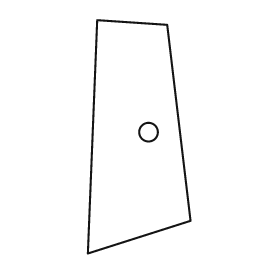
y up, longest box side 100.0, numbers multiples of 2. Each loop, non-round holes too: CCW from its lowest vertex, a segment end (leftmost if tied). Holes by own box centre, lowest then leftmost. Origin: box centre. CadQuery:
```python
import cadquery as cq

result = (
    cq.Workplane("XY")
    .moveTo(-22.0, -50.0)
    .lineTo(22.0, -36.0)
    .lineTo(12.0, 48.0)
    .lineTo(-18.0, 50.0)
    .close()
    .moveTo(4.0, 2.0)
    .circle(4.0)
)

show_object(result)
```